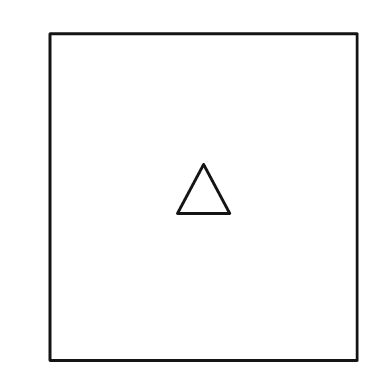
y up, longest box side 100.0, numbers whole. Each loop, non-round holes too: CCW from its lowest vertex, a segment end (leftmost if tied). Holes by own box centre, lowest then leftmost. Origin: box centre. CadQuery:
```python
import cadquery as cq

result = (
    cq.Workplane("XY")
    .moveTo(-47.0, -50.0)
    .lineTo(47.0, -50.0)
    .lineTo(47.0, 50.0)
    .lineTo(-47.0, 50.0)
    .close()
    .moveTo(-8.0, -5.0)
    .lineTo(8.0, -5.0)
    .lineTo(0.0, 10.0)
    .close()
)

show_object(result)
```